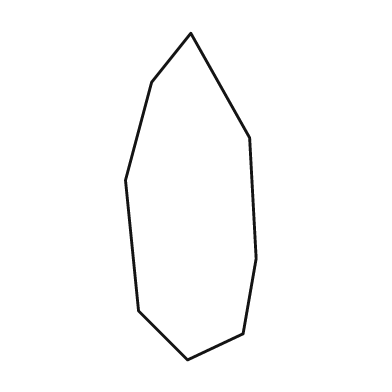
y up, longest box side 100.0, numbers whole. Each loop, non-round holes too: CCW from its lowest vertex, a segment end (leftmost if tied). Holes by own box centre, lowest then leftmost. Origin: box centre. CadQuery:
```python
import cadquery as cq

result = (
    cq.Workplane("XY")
    .moveTo(-1.0, -50.0)
    .lineTo(16.0, -42.0)
    .lineTo(20.0, -19.0)
    .lineTo(18.0, 18.0)
    .lineTo(0.0, 50.0)
    .lineTo(-12.0, 35.0)
    .lineTo(-20.0, 5.0)
    .lineTo(-16.0, -35.0)
    .close()
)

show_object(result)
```